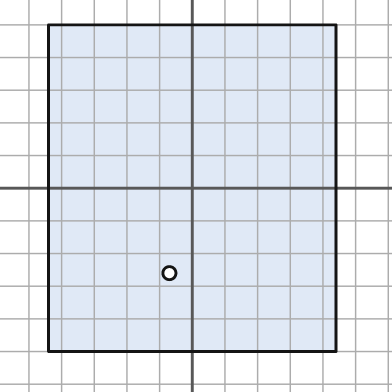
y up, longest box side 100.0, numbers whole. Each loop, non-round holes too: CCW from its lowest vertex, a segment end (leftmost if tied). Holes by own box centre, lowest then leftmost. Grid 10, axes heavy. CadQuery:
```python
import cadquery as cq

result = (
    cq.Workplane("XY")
    .moveTo(-44.0, -50.0)
    .lineTo(44.0, -50.0)
    .lineTo(44.0, 50.0)
    .lineTo(-44.0, 50.0)
    .close()
    .moveTo(-7.0, -26.0)
    .circle(2.0)
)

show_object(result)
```